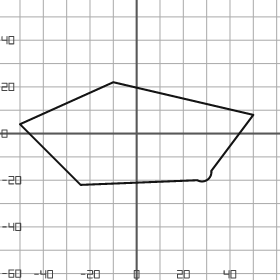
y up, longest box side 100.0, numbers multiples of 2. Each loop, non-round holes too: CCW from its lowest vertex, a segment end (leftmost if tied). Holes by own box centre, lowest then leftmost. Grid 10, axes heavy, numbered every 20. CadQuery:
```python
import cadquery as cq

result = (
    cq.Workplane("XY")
    .moveTo(-24.0, -22.0)
    .lineTo(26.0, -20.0)
    .threePointArc((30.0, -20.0), (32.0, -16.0))
    .lineTo(50.0, 8.0)
    .lineTo(-10.0, 22.0)
    .lineTo(-50.0, 4.0)
    .close()
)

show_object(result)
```